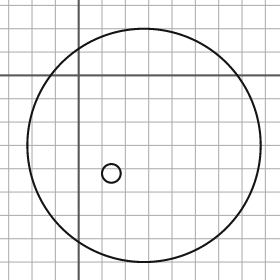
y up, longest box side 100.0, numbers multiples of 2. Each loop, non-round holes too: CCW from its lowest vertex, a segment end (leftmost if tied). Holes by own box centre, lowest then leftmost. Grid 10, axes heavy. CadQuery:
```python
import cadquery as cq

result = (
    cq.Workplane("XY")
    .moveTo(28.0, -30.0)
    .circle(50.0)
    .moveTo(14.0, -42.0)
    .circle(4.0)
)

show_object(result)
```